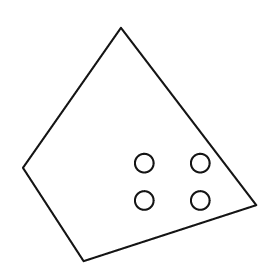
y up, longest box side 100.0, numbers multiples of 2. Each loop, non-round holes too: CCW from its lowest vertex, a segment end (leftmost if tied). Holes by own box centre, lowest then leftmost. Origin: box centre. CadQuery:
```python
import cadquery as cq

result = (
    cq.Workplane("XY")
    .moveTo(-24.0, -50.0)
    .lineTo(50.0, -26.0)
    .lineTo(-8.0, 50.0)
    .lineTo(-50.0, -10.0)
    .close()
    .moveTo(2.0, -24.0)
    .circle(4.0)
    .moveTo(26.0, -24.0)
    .circle(4.0)
    .moveTo(2.0, -8.0)
    .circle(4.0)
    .moveTo(26.0, -8.0)
    .circle(4.0)
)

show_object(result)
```